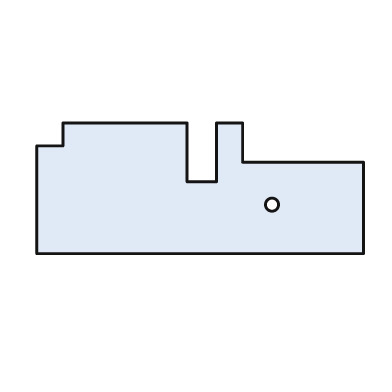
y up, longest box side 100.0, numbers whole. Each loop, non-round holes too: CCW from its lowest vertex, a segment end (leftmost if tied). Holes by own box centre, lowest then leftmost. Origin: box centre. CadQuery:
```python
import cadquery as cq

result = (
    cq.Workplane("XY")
    .moveTo(-50.0, -20.0)
    .lineTo(50.0, -20.0)
    .lineTo(50.0, 8.0)
    .lineTo(13.0, 8.0)
    .lineTo(13.0, 20.0)
    .lineTo(5.0, 20.0)
    .lineTo(5.0, 2.0)
    .lineTo(-4.0, 2.0)
    .lineTo(-4.0, 20.0)
    .lineTo(-42.0, 20.0)
    .lineTo(-42.0, 13.0)
    .lineTo(-50.0, 13.0)
    .close()
    .moveTo(22.0, -5.0)
    .circle(2.0)
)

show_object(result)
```